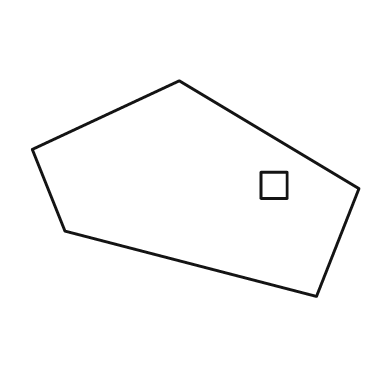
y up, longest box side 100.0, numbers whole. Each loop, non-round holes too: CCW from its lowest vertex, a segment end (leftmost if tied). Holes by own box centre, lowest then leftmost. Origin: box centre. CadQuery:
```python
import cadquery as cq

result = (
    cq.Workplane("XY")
    .moveTo(37.0, -33.0)
    .lineTo(50.0, 0.0)
    .lineTo(-5.0, 33.0)
    .lineTo(-50.0, 12.0)
    .lineTo(-40.0, -13.0)
    .close()
    .moveTo(20.0, -3.0)
    .lineTo(28.0, -3.0)
    .lineTo(28.0, 5.0)
    .lineTo(20.0, 5.0)
    .close()
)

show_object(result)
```